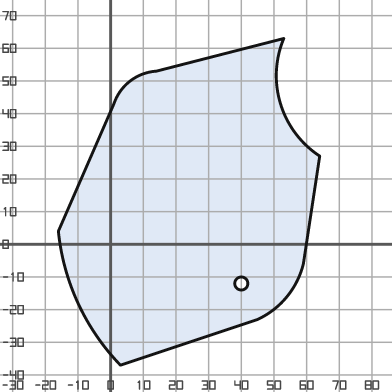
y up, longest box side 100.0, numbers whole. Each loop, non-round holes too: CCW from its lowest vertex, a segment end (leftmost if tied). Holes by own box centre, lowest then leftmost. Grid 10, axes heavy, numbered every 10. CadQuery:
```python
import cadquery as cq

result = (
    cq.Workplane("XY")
    .moveTo(3.0, -37.0)
    .lineTo(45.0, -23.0)
    .threePointArc((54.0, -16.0), (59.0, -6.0))
    .lineTo(64.0, 27.0)
    .threePointArc((52.0, 43.0), (53.0, 63.0))
    .lineTo(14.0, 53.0)
    .threePointArc((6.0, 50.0), (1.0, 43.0))
    .lineTo(-16.0, 4.0)
    .threePointArc((-10.0, -18.0), (3.0, -37.0))
    .close()
    .moveTo(40.0, -12.0)
    .circle(2.0)
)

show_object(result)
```